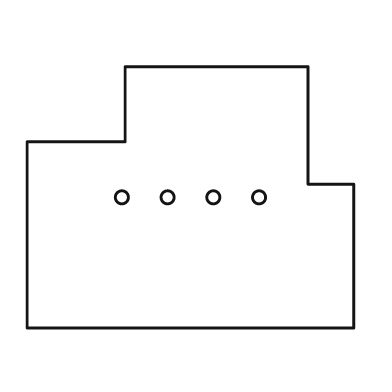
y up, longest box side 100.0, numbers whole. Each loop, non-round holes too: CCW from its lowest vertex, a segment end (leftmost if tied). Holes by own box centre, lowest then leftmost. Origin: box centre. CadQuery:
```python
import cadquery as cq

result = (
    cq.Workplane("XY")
    .moveTo(-50.0, -40.0)
    .lineTo(50.0, -40.0)
    .lineTo(50.0, 4.0)
    .lineTo(36.0, 4.0)
    .lineTo(36.0, 40.0)
    .lineTo(-20.0, 40.0)
    .lineTo(-20.0, 17.0)
    .lineTo(-50.0, 17.0)
    .close()
    .moveTo(-21.0, 0.0)
    .circle(2.0)
    .moveTo(-7.0, 0.0)
    .circle(2.0)
    .moveTo(7.0, 0.0)
    .circle(2.0)
    .moveTo(21.0, 0.0)
    .circle(2.0)
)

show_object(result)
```